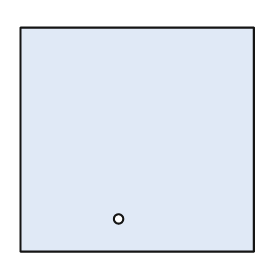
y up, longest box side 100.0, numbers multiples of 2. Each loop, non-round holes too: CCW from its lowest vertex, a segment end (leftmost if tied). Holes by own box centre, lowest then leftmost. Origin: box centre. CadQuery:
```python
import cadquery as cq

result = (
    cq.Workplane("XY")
    .moveTo(-50.0, -48.0)
    .lineTo(50.0, -48.0)
    .lineTo(50.0, 48.0)
    .lineTo(-50.0, 48.0)
    .close()
    .moveTo(-8.0, -34.0)
    .circle(2.0)
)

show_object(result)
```